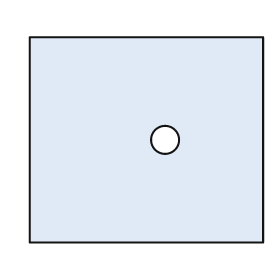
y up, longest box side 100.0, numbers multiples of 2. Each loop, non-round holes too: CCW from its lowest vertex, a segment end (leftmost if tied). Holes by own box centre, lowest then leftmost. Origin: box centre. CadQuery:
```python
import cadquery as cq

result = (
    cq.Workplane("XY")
    .moveTo(-50.0, -44.0)
    .lineTo(50.0, -44.0)
    .lineTo(50.0, 44.0)
    .lineTo(-50.0, 44.0)
    .close()
    .moveTo(8.0, 0.0)
    .circle(6.0)
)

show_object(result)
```